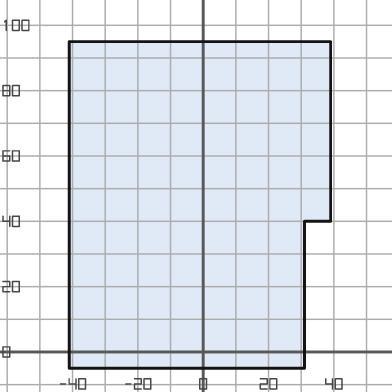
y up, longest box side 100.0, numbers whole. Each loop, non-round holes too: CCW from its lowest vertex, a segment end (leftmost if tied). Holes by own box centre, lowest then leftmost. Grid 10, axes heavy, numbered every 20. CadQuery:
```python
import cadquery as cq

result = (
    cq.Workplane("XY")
    .moveTo(-41.0, -5.0)
    .lineTo(31.0, -5.0)
    .lineTo(31.0, 40.0)
    .lineTo(39.0, 40.0)
    .lineTo(39.0, 95.0)
    .lineTo(-41.0, 95.0)
    .close()
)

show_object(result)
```